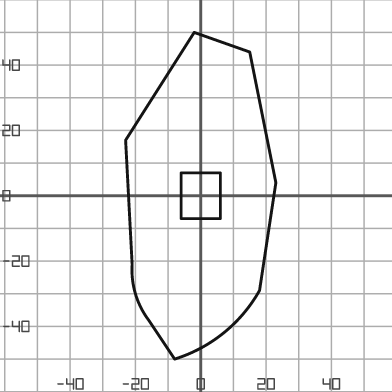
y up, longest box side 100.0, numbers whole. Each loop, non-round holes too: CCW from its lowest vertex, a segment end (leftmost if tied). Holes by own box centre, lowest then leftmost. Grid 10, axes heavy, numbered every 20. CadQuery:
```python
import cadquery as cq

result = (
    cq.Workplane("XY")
    .moveTo(-8.0, -50.0)
    .threePointArc((7.0, -42.0), (18.0, -29.0))
    .lineTo(23.0, 4.0)
    .lineTo(15.0, 44.0)
    .lineTo(-2.0, 50.0)
    .lineTo(-23.0, 17.0)
    .lineTo(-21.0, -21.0)
    .threePointArc((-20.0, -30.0), (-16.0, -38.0))
    .close()
    .moveTo(-6.0, -7.0)
    .lineTo(6.0, -7.0)
    .lineTo(6.0, 7.0)
    .lineTo(-6.0, 7.0)
    .close()
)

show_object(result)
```